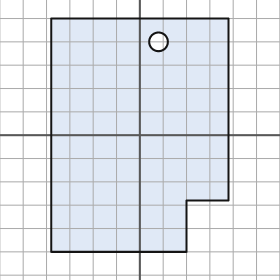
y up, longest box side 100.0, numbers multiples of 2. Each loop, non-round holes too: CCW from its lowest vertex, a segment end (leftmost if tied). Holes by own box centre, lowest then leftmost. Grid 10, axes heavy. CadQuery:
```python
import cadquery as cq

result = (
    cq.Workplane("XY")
    .moveTo(-38.0, -50.0)
    .lineTo(20.0, -50.0)
    .lineTo(20.0, -28.0)
    .lineTo(38.0, -28.0)
    .lineTo(38.0, 50.0)
    .lineTo(-38.0, 50.0)
    .close()
    .moveTo(8.0, 40.0)
    .circle(4.0)
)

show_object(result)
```